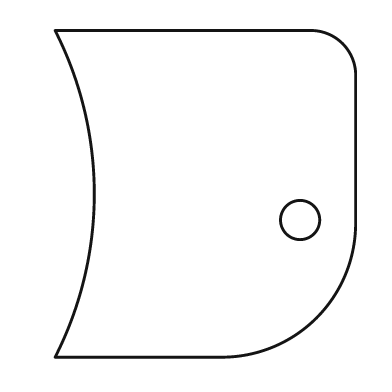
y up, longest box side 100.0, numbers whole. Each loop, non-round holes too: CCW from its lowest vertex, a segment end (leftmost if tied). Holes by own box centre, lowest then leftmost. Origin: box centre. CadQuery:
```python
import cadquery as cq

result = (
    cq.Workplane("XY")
    .moveTo(-46.0, -50.0)
    .lineTo(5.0, -50.0)
    .threePointArc((34.0, -38.0), (46.0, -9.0))
    .lineTo(46.0, 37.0)
    .threePointArc((42.0, 46.0), (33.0, 50.0))
    .lineTo(-46.0, 50.0)
    .threePointArc((-34.0, 0.0), (-46.0, -50.0))
    .close()
    .moveTo(29.0, -8.0)
    .circle(6.0)
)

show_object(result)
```